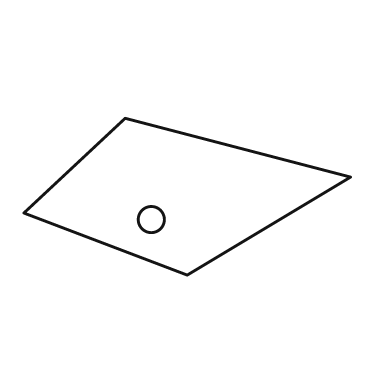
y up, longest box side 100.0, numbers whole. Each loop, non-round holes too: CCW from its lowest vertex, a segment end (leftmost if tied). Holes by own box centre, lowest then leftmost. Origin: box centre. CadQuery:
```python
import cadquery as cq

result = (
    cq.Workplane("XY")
    .moveTo(0.0, -24.0)
    .lineTo(50.0, 6.0)
    .lineTo(-19.0, 24.0)
    .lineTo(-50.0, -5.0)
    .close()
    .moveTo(-11.0, -7.0)
    .circle(4.0)
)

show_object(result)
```